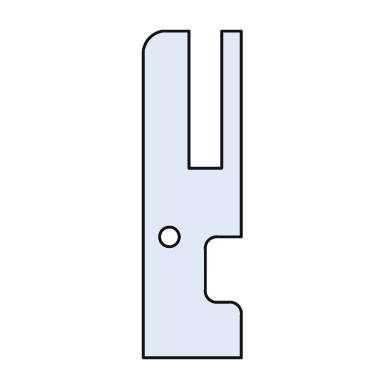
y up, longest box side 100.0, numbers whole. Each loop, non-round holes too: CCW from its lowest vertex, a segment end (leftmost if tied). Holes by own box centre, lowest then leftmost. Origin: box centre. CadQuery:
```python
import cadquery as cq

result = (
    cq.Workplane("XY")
    .moveTo(-15.0, -50.0)
    .lineTo(15.0, -50.0)
    .lineTo(15.0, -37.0)
    .threePointArc((14.0, -34.0), (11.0, -33.0))
    .lineTo(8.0, -33.0)
    .threePointArc((5.0, -32.0), (4.0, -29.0))
    .lineTo(4.0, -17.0)
    .threePointArc((5.0, -14.0), (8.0, -13.0))
    .lineTo(15.0, -13.0)
    .lineTo(15.0, 50.0)
    .lineTo(9.0, 50.0)
    .lineTo(9.0, 8.0)
    .lineTo(-1.0, 8.0)
    .lineTo(-1.0, 50.0)
    .lineTo(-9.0, 50.0)
    .threePointArc((-13.0, 48.0), (-15.0, 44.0))
    .close()
    .moveTo(-7.0, -13.0)
    .circle(3.0)
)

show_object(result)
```